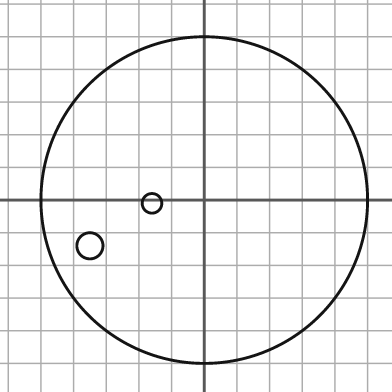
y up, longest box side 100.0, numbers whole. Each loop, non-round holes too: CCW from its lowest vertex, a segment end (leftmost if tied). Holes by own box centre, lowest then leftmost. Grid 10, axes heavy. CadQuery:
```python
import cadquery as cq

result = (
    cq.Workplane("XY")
    .moveTo(0.0, 0.0)
    .circle(50.0)
    .moveTo(-35.0, -14.0)
    .circle(4.0)
    .moveTo(-16.0, -1.0)
    .circle(3.0)
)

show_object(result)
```